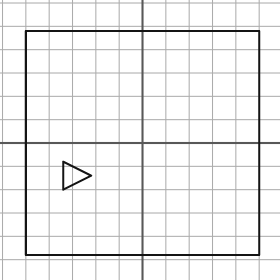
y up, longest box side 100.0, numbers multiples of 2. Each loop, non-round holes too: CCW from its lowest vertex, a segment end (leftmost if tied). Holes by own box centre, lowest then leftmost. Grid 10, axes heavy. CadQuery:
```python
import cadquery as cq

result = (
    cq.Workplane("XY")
    .moveTo(-50.0, -48.0)
    .lineTo(50.0, -48.0)
    .lineTo(50.0, 48.0)
    .lineTo(-50.0, 48.0)
    .close()
    .moveTo(-34.0, -20.0)
    .lineTo(-22.0, -14.0)
    .lineTo(-34.0, -8.0)
    .close()
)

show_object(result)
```